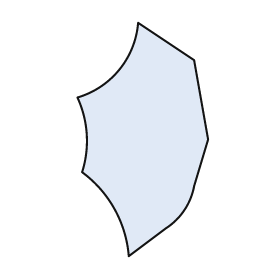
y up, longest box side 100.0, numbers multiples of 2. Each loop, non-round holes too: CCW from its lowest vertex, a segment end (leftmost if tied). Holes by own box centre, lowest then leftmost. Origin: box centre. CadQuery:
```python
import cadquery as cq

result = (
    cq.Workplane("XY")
    .moveTo(-6.0, -50.0)
    .lineTo(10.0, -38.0)
    .threePointArc((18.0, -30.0), (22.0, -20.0))
    .lineTo(28.0, 0.0)
    .lineTo(22.0, 34.0)
    .lineTo(-2.0, 50.0)
    .threePointArc((-10.0, 30.0), (-28.0, 18.0))
    .threePointArc((-24.0, 2.0), (-26.0, -14.0))
    .threePointArc((-12.0, -30.0), (-6.0, -50.0))
    .close()
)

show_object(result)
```